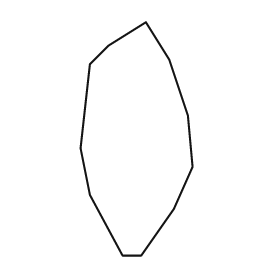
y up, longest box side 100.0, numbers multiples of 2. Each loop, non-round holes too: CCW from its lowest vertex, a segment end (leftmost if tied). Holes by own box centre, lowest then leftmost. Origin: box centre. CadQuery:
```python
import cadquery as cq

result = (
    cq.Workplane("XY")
    .moveTo(-6.0, -50.0)
    .lineTo(2.0, -50.0)
    .lineTo(16.0, -30.0)
    .lineTo(24.0, -12.0)
    .lineTo(22.0, 10.0)
    .lineTo(14.0, 34.0)
    .lineTo(4.0, 50.0)
    .lineTo(-12.0, 40.0)
    .lineTo(-20.0, 32.0)
    .lineTo(-24.0, -4.0)
    .lineTo(-20.0, -24.0)
    .close()
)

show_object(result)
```